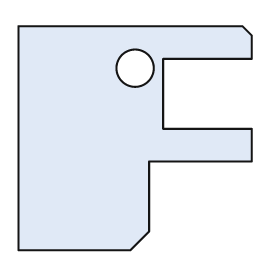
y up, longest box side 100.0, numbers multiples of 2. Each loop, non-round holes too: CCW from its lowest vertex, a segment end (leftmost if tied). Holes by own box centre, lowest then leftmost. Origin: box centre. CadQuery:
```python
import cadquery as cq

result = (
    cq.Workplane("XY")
    .moveTo(-50.0, -48.0)
    .lineTo(-2.0, -48.0)
    .lineTo(6.0, -40.0)
    .lineTo(6.0, -10.0)
    .lineTo(50.0, -10.0)
    .lineTo(50.0, 4.0)
    .lineTo(12.0, 4.0)
    .lineTo(12.0, 34.0)
    .lineTo(50.0, 34.0)
    .lineTo(50.0, 44.0)
    .lineTo(46.0, 48.0)
    .lineTo(-50.0, 48.0)
    .close()
    .moveTo(0.0, 30.0)
    .circle(8.0)
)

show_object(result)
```